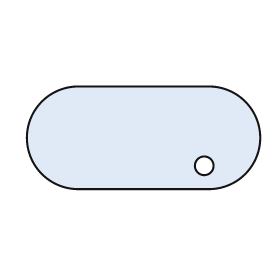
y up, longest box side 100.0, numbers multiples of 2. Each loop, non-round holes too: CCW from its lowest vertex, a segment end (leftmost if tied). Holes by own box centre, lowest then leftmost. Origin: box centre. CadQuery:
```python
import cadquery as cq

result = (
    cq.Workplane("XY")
    .moveTo(-28.0, -22.0)
    .lineTo(28.0, -22.0)
    .threePointArc((50.0, 0.0), (28.0, 22.0))
    .lineTo(-28.0, 22.0)
    .threePointArc((-50.0, 0.0), (-28.0, -22.0))
    .close()
    .moveTo(26.0, -12.0)
    .circle(4.0)
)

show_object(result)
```